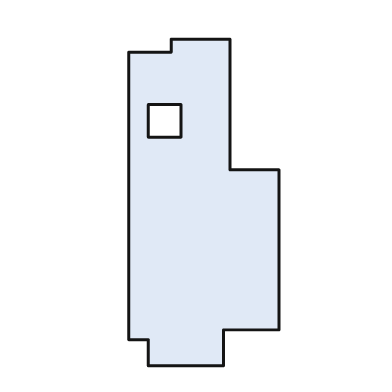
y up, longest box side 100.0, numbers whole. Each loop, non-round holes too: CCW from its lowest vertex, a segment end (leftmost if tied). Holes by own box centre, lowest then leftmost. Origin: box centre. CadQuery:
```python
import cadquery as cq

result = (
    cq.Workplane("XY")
    .moveTo(-17.0, -50.0)
    .lineTo(6.0, -50.0)
    .lineTo(6.0, -39.0)
    .lineTo(23.0, -39.0)
    .lineTo(23.0, 10.0)
    .lineTo(8.0, 10.0)
    .lineTo(8.0, 50.0)
    .lineTo(-10.0, 50.0)
    .lineTo(-10.0, 46.0)
    .lineTo(-23.0, 46.0)
    .lineTo(-23.0, -42.0)
    .lineTo(-17.0, -42.0)
    .close()
    .moveTo(-17.0, 20.0)
    .lineTo(-7.0, 20.0)
    .lineTo(-7.0, 30.0)
    .lineTo(-17.0, 30.0)
    .close()
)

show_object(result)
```